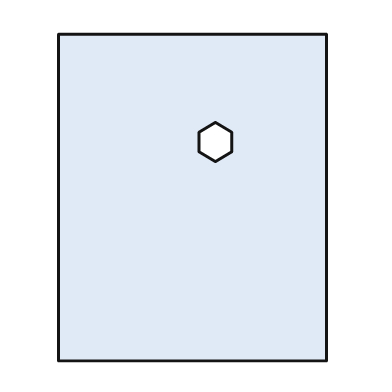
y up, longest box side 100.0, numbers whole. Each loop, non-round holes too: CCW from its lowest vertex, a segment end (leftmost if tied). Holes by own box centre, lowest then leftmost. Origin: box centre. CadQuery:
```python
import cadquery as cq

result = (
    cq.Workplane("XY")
    .moveTo(-41.0, -50.0)
    .lineTo(41.0, -50.0)
    .lineTo(41.0, 50.0)
    .lineTo(-41.0, 50.0)
    .close()
    .moveTo(7.0, 11.0)
    .lineTo(12.0, 14.0)
    .lineTo(12.0, 20.0)
    .lineTo(7.0, 23.0)
    .lineTo(2.0, 20.0)
    .lineTo(2.0, 14.0)
    .close()
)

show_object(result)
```